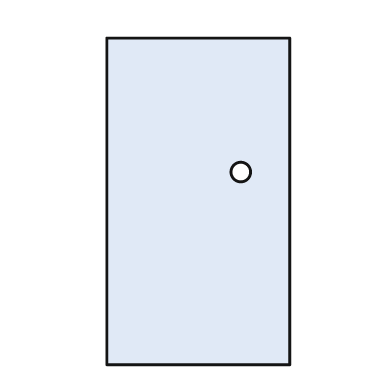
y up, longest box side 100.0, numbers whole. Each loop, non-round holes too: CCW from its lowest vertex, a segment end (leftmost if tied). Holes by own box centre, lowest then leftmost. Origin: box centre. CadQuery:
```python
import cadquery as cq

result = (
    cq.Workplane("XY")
    .moveTo(-28.0, -50.0)
    .lineTo(28.0, -50.0)
    .lineTo(28.0, 50.0)
    .lineTo(-28.0, 50.0)
    .close()
    .moveTo(13.0, 9.0)
    .circle(3.0)
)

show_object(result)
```